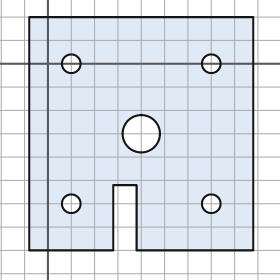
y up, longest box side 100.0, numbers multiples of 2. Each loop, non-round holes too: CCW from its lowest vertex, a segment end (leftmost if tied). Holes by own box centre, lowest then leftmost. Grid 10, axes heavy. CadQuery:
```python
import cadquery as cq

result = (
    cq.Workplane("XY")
    .moveTo(-8.0, -80.0)
    .lineTo(28.0, -80.0)
    .lineTo(28.0, -52.0)
    .lineTo(38.0, -52.0)
    .lineTo(38.0, -80.0)
    .lineTo(88.0, -80.0)
    .lineTo(88.0, 20.0)
    .lineTo(-8.0, 20.0)
    .close()
    .moveTo(10.0, -60.0)
    .circle(4.0)
    .moveTo(70.0, -60.0)
    .circle(4.0)
    .moveTo(40.0, -30.0)
    .circle(8.0)
    .moveTo(10.0, 0.0)
    .circle(4.0)
    .moveTo(70.0, 0.0)
    .circle(4.0)
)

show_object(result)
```